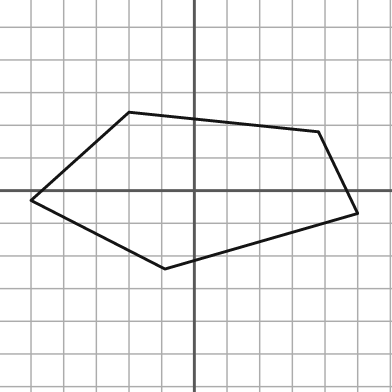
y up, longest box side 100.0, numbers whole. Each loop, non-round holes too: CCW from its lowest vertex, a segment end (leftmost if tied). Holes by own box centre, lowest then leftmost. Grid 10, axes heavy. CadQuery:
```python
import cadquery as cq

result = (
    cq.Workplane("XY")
    .moveTo(-9.0, -24.0)
    .lineTo(50.0, -7.0)
    .lineTo(38.0, 18.0)
    .lineTo(-20.0, 24.0)
    .lineTo(-50.0, -3.0)
    .close()
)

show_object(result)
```